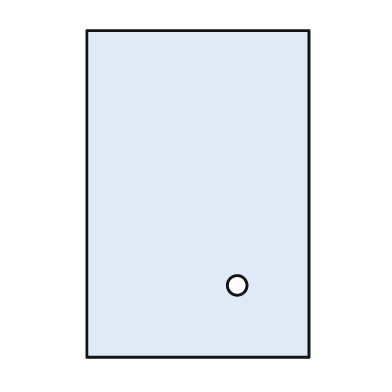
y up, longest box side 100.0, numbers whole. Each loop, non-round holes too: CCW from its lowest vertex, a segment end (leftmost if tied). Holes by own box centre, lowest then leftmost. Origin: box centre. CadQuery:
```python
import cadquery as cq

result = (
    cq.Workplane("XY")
    .moveTo(-34.0, -50.0)
    .lineTo(34.0, -50.0)
    .lineTo(34.0, 50.0)
    .lineTo(-34.0, 50.0)
    .close()
    .moveTo(12.0, -28.0)
    .circle(3.0)
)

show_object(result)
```